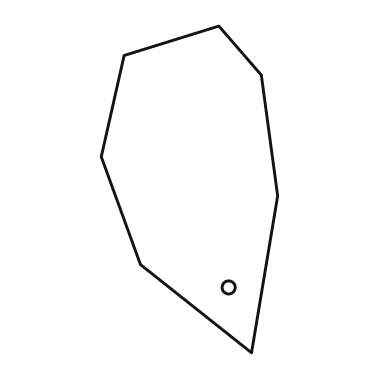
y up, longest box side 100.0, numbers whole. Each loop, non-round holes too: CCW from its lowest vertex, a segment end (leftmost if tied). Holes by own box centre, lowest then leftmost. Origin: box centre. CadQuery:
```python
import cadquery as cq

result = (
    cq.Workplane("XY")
    .moveTo(19.0, -50.0)
    .lineTo(27.0, -2.0)
    .lineTo(22.0, 35.0)
    .lineTo(9.0, 50.0)
    .lineTo(-20.0, 41.0)
    .lineTo(-27.0, 10.0)
    .lineTo(-15.0, -23.0)
    .close()
    .moveTo(12.0, -30.0)
    .circle(2.0)
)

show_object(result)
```